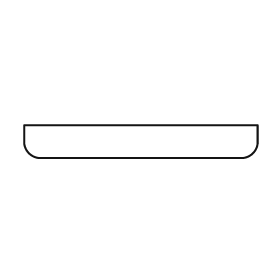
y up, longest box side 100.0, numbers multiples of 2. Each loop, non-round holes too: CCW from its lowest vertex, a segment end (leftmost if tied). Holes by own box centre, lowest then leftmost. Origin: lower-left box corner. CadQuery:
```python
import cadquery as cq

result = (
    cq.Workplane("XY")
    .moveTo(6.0, 0.0)
    .lineTo(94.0, 0.0)
    .threePointArc((98.0, 2.0), (100.0, 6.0))
    .lineTo(100.0, 14.0)
    .lineTo(0.0, 14.0)
    .lineTo(0.0, 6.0)
    .threePointArc((2.0, 2.0), (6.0, 0.0))
    .close()
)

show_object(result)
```